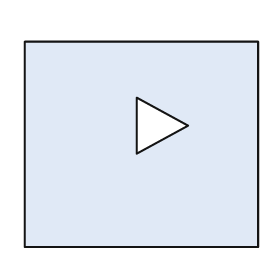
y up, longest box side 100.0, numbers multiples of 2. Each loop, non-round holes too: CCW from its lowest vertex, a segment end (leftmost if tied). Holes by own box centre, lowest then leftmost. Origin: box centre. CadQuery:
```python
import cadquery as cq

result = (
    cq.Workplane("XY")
    .moveTo(-50.0, -44.0)
    .lineTo(50.0, -44.0)
    .lineTo(50.0, 44.0)
    .lineTo(-50.0, 44.0)
    .close()
    .moveTo(-2.0, -4.0)
    .lineTo(20.0, 8.0)
    .lineTo(-2.0, 20.0)
    .close()
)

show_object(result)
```